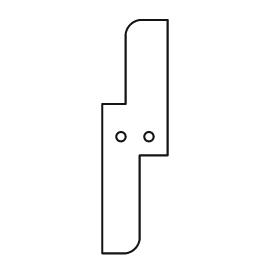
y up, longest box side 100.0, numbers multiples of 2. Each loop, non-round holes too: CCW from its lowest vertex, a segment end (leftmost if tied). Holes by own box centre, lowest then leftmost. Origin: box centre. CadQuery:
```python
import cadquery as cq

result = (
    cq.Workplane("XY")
    .moveTo(-14.0, -50.0)
    .lineTo(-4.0, -50.0)
    .threePointArc((0.0, -48.0), (2.0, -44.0))
    .lineTo(2.0, -8.0)
    .lineTo(14.0, -8.0)
    .lineTo(14.0, 50.0)
    .lineTo(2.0, 50.0)
    .threePointArc((-2.0, 48.0), (-4.0, 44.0))
    .lineTo(-4.0, 14.0)
    .lineTo(-14.0, 14.0)
    .close()
    .moveTo(-6.0, 0.0)
    .circle(2.0)
    .moveTo(6.0, 0.0)
    .circle(2.0)
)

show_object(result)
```